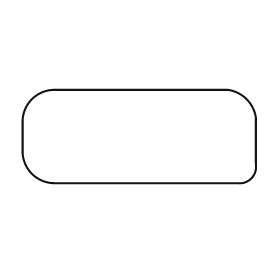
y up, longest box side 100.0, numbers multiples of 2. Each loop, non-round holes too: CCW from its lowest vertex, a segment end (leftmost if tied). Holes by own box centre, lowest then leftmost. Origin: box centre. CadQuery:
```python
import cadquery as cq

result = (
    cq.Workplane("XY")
    .moveTo(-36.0, -20.0)
    .lineTo(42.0, -20.0)
    .threePointArc((48.0, -18.0), (50.0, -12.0))
    .lineTo(50.0, 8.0)
    .threePointArc((46.0, 16.0), (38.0, 20.0))
    .lineTo(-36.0, 20.0)
    .threePointArc((-46.0, 16.0), (-50.0, 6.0))
    .lineTo(-50.0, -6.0)
    .threePointArc((-46.0, -16.0), (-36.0, -20.0))
    .close()
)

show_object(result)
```